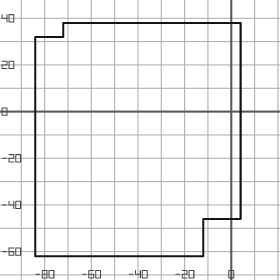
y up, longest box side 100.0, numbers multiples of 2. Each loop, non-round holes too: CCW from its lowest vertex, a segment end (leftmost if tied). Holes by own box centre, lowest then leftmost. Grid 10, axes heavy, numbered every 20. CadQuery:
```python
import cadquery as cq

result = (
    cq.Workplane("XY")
    .moveTo(-84.0, -62.0)
    .lineTo(-12.0, -62.0)
    .lineTo(-12.0, -46.0)
    .lineTo(4.0, -46.0)
    .lineTo(4.0, 38.0)
    .lineTo(-72.0, 38.0)
    .lineTo(-72.0, 32.0)
    .lineTo(-84.0, 32.0)
    .close()
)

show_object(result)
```